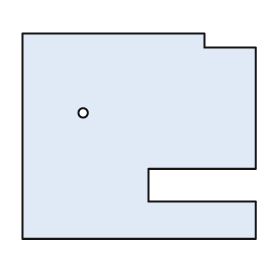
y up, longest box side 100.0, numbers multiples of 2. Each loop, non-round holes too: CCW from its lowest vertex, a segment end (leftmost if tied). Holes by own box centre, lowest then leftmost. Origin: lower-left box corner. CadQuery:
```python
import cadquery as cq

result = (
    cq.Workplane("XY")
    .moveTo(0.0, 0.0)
    .lineTo(100.0, 0.0)
    .lineTo(100.0, 16.0)
    .lineTo(54.0, 16.0)
    .lineTo(54.0, 30.0)
    .lineTo(100.0, 30.0)
    .lineTo(100.0, 82.0)
    .lineTo(78.0, 82.0)
    .lineTo(78.0, 88.0)
    .lineTo(0.0, 88.0)
    .close()
    .moveTo(26.0, 54.0)
    .circle(2.0)
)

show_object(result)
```